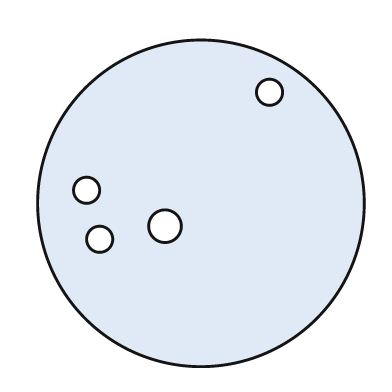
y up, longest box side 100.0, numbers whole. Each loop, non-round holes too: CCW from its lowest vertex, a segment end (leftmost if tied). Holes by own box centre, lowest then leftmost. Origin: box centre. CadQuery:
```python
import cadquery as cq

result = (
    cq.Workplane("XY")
    .moveTo(0.0, 0.0)
    .circle(50.0)
    .moveTo(-31.0, -11.0)
    .circle(4.0)
    .moveTo(-11.0, -7.0)
    .circle(5.0)
    .moveTo(-35.0, 4.0)
    .circle(4.0)
    .moveTo(21.0, 34.0)
    .circle(4.0)
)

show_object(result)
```